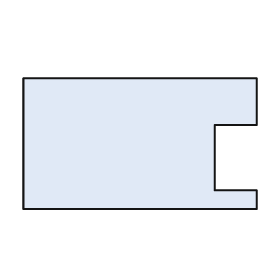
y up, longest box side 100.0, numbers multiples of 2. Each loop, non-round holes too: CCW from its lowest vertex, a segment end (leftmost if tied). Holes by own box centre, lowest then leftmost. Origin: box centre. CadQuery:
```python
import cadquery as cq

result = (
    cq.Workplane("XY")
    .moveTo(-50.0, -28.0)
    .lineTo(50.0, -28.0)
    .lineTo(50.0, -20.0)
    .lineTo(32.0, -20.0)
    .lineTo(32.0, 8.0)
    .lineTo(50.0, 8.0)
    .lineTo(50.0, 28.0)
    .lineTo(-50.0, 28.0)
    .close()
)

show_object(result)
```